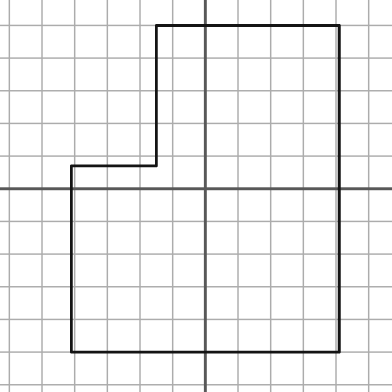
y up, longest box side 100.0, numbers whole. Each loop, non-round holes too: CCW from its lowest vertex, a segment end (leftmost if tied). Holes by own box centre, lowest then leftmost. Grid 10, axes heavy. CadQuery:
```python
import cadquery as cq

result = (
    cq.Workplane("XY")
    .moveTo(-41.0, -50.0)
    .lineTo(41.0, -50.0)
    .lineTo(41.0, 50.0)
    .lineTo(-15.0, 50.0)
    .lineTo(-15.0, 7.0)
    .lineTo(-41.0, 7.0)
    .close()
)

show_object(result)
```